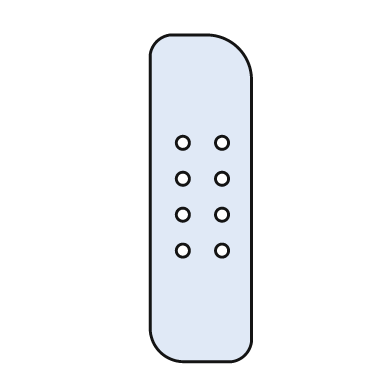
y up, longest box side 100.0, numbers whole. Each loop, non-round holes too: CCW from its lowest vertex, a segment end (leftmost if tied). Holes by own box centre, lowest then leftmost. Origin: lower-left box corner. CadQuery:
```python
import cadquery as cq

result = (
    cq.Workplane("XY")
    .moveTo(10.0, 0.0)
    .lineTo(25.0, 0.0)
    .threePointArc((29.0, 2.0), (31.0, 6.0))
    .lineTo(31.0, 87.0)
    .threePointArc((27.0, 96.0), (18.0, 100.0))
    .lineTo(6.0, 100.0)
    .threePointArc((2.0, 98.0), (0.0, 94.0))
    .lineTo(0.0, 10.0)
    .threePointArc((3.0, 3.0), (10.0, 0.0))
    .close()
    .moveTo(10.0, 34.0)
    .circle(2.0)
    .moveTo(22.0, 34.0)
    .circle(2.0)
    .moveTo(10.0, 45.0)
    .circle(2.0)
    .moveTo(22.0, 45.0)
    .circle(2.0)
    .moveTo(10.0, 56.0)
    .circle(2.0)
    .moveTo(22.0, 56.0)
    .circle(2.0)
    .moveTo(10.0, 67.0)
    .circle(2.0)
    .moveTo(22.0, 67.0)
    .circle(2.0)
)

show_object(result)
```